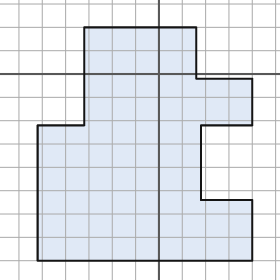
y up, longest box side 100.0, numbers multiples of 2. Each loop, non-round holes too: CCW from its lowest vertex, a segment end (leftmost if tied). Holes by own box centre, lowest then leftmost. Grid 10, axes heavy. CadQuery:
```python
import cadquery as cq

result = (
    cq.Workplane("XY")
    .moveTo(-52.0, -80.0)
    .lineTo(40.0, -80.0)
    .lineTo(40.0, -54.0)
    .lineTo(18.0, -54.0)
    .lineTo(18.0, -22.0)
    .lineTo(40.0, -22.0)
    .lineTo(40.0, -2.0)
    .lineTo(16.0, -2.0)
    .lineTo(16.0, 20.0)
    .lineTo(-32.0, 20.0)
    .lineTo(-32.0, -22.0)
    .lineTo(-52.0, -22.0)
    .close()
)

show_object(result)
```